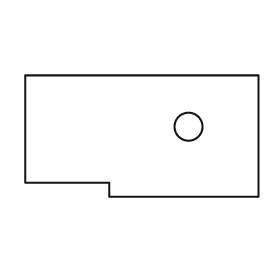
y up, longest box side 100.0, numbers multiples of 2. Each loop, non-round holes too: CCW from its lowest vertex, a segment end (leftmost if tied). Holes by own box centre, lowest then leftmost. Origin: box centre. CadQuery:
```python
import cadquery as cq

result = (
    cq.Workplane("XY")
    .moveTo(-14.0, -26.0)
    .lineTo(50.0, -26.0)
    .lineTo(50.0, 26.0)
    .lineTo(-50.0, 26.0)
    .lineTo(-50.0, -20.0)
    .lineTo(-14.0, -20.0)
    .close()
    .moveTo(20.0, 4.0)
    .circle(6.0)
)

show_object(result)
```